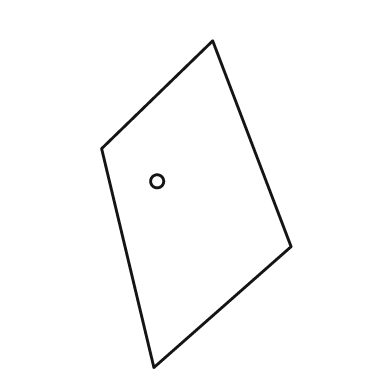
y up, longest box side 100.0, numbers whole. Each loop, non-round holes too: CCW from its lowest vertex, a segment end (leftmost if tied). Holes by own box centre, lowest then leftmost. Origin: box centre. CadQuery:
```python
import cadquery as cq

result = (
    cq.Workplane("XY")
    .moveTo(-13.0, -50.0)
    .lineTo(29.0, -13.0)
    .lineTo(5.0, 50.0)
    .lineTo(-29.0, 17.0)
    .close()
    .moveTo(-12.0, 7.0)
    .circle(2.0)
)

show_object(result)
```